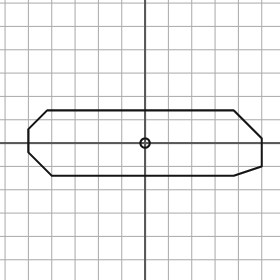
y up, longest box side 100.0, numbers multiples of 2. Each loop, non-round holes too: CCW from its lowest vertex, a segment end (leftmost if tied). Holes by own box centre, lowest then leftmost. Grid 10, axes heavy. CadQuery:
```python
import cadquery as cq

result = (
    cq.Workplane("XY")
    .moveTo(-40.0, -14.0)
    .lineTo(38.0, -14.0)
    .lineTo(50.0, -10.0)
    .lineTo(50.0, 2.0)
    .lineTo(38.0, 14.0)
    .lineTo(-42.0, 14.0)
    .lineTo(-50.0, 6.0)
    .lineTo(-50.0, -4.0)
    .close()
    .moveTo(0.0, 0.0)
    .circle(2.0)
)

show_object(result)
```